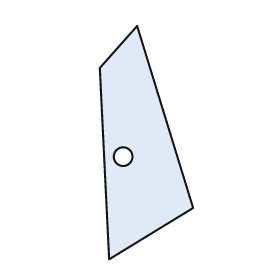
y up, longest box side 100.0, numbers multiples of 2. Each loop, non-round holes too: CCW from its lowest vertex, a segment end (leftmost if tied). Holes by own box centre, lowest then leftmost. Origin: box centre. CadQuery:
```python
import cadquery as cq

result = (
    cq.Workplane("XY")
    .moveTo(-16.0, -50.0)
    .lineTo(20.0, -28.0)
    .lineTo(-4.0, 50.0)
    .lineTo(-20.0, 32.0)
    .close()
    .moveTo(-10.0, -6.0)
    .circle(4.0)
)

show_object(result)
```